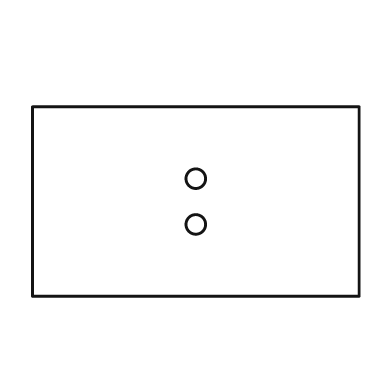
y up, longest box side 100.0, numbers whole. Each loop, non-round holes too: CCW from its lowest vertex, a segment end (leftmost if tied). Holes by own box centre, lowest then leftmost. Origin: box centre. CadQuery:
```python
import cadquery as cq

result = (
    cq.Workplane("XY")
    .moveTo(-50.0, -29.0)
    .lineTo(50.0, -29.0)
    .lineTo(50.0, 29.0)
    .lineTo(-50.0, 29.0)
    .close()
    .moveTo(0.0, -7.0)
    .circle(3.0)
    .moveTo(0.0, 7.0)
    .circle(3.0)
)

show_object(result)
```